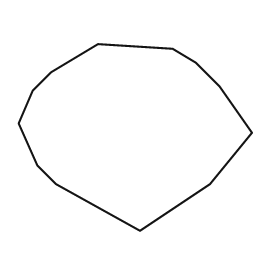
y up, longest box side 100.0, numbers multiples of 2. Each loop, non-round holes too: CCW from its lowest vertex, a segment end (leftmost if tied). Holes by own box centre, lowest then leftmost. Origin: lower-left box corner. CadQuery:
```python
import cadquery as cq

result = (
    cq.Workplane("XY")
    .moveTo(52.0, 0.0)
    .lineTo(82.0, 20.0)
    .lineTo(100.0, 42.0)
    .lineTo(86.0, 62.0)
    .lineTo(76.0, 72.0)
    .lineTo(66.0, 78.0)
    .lineTo(34.0, 80.0)
    .lineTo(14.0, 68.0)
    .lineTo(6.0, 60.0)
    .lineTo(0.0, 46.0)
    .lineTo(8.0, 28.0)
    .lineTo(16.0, 20.0)
    .close()
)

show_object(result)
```